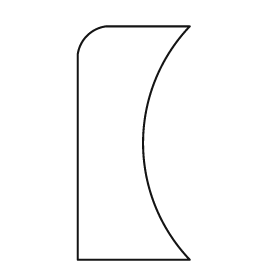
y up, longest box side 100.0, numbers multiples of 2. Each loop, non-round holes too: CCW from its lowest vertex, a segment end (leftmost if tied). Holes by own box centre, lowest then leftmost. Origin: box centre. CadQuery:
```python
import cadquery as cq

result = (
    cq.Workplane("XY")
    .moveTo(-24.0, -50.0)
    .lineTo(24.0, -50.0)
    .threePointArc((4.0, 0.0), (24.0, 50.0))
    .lineTo(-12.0, 50.0)
    .threePointArc((-20.0, 46.0), (-24.0, 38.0))
    .close()
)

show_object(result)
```